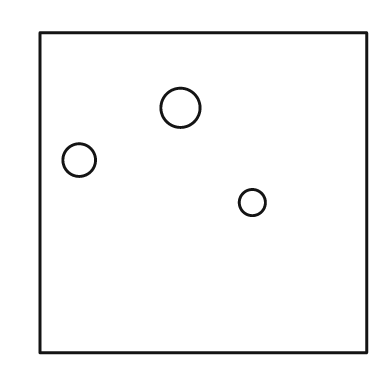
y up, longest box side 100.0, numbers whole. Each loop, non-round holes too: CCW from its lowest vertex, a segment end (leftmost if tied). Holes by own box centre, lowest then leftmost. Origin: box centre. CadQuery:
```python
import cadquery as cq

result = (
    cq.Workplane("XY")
    .moveTo(-50.0, -49.0)
    .lineTo(50.0, -49.0)
    .lineTo(50.0, 49.0)
    .lineTo(-50.0, 49.0)
    .close()
    .moveTo(15.0, -3.0)
    .circle(4.0)
    .moveTo(-38.0, 10.0)
    .circle(5.0)
    .moveTo(-7.0, 26.0)
    .circle(6.0)
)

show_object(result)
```